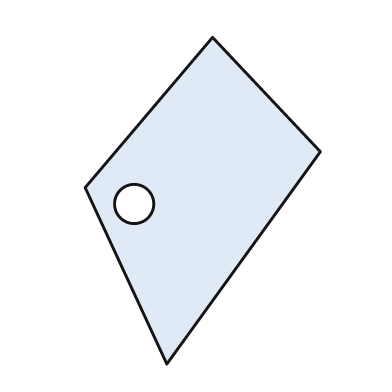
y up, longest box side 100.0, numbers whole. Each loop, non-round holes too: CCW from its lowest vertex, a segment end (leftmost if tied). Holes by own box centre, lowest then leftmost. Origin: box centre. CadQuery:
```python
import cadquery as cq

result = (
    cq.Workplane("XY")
    .moveTo(-11.0, -50.0)
    .lineTo(36.0, 15.0)
    .lineTo(3.0, 50.0)
    .lineTo(-36.0, 4.0)
    .close()
    .moveTo(-21.0, -1.0)
    .circle(6.0)
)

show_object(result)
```